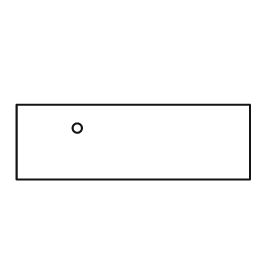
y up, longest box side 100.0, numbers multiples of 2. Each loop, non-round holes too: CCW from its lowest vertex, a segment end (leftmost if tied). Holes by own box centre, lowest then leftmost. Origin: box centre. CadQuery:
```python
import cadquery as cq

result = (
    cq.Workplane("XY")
    .moveTo(-50.0, -16.0)
    .lineTo(50.0, -16.0)
    .lineTo(50.0, 16.0)
    .lineTo(-50.0, 16.0)
    .close()
    .moveTo(-24.0, 6.0)
    .circle(2.0)
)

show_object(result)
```